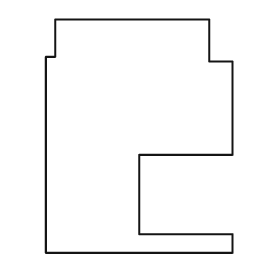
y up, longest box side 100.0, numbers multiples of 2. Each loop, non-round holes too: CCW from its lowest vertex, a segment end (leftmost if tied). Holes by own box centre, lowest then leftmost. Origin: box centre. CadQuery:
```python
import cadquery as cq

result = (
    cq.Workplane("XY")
    .moveTo(-40.0, -50.0)
    .lineTo(40.0, -50.0)
    .lineTo(40.0, -42.0)
    .lineTo(0.0, -42.0)
    .lineTo(0.0, -8.0)
    .lineTo(40.0, -8.0)
    .lineTo(40.0, 32.0)
    .lineTo(30.0, 32.0)
    .lineTo(30.0, 50.0)
    .lineTo(-36.0, 50.0)
    .lineTo(-36.0, 34.0)
    .lineTo(-40.0, 34.0)
    .close()
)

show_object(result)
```